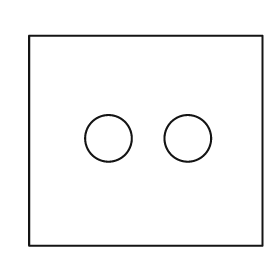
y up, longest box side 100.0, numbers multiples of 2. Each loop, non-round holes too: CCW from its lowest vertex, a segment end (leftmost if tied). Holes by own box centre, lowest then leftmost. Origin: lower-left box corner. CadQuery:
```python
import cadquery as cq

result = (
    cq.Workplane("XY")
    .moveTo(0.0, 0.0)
    .lineTo(100.0, 0.0)
    .lineTo(100.0, 90.0)
    .lineTo(0.0, 90.0)
    .close()
    .moveTo(34.0, 46.0)
    .circle(10.0)
    .moveTo(68.0, 46.0)
    .circle(10.0)
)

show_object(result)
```